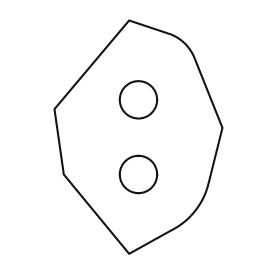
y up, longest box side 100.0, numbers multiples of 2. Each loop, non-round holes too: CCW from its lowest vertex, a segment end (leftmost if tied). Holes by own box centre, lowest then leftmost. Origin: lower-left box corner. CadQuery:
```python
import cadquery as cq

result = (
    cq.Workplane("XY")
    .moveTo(32.0, 0.0)
    .lineTo(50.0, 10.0)
    .threePointArc((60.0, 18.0), (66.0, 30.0))
    .lineTo(72.0, 54.0)
    .lineTo(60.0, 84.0)
    .threePointArc((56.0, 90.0), (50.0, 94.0))
    .lineTo(32.0, 100.0)
    .lineTo(0.0, 62.0)
    .lineTo(4.0, 34.0)
    .close()
    .moveTo(36.0, 34.0)
    .circle(8.0)
    .moveTo(36.0, 66.0)
    .circle(8.0)
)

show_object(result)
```